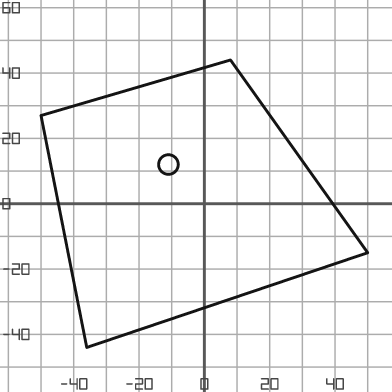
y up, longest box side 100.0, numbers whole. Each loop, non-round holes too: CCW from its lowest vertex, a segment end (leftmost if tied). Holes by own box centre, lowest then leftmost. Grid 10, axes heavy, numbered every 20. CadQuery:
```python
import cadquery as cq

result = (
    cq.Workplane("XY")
    .moveTo(-36.0, -44.0)
    .lineTo(50.0, -15.0)
    .lineTo(8.0, 44.0)
    .lineTo(-50.0, 27.0)
    .close()
    .moveTo(-11.0, 12.0)
    .circle(3.0)
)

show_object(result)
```